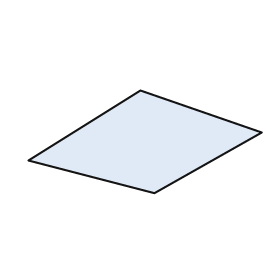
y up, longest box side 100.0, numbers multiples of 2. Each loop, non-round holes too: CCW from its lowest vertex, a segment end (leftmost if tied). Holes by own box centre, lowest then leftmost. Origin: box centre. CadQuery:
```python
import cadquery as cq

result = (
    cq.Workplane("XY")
    .moveTo(4.0, -22.0)
    .lineTo(50.0, 4.0)
    .lineTo(-2.0, 22.0)
    .lineTo(-50.0, -8.0)
    .close()
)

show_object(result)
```